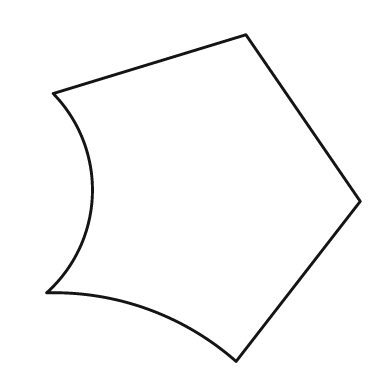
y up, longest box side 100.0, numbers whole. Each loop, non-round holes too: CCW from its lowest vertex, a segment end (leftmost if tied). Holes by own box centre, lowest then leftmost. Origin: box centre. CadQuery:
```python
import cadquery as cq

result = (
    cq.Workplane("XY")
    .moveTo(10.0, -50.0)
    .lineTo(48.0, -1.0)
    .lineTo(13.0, 50.0)
    .lineTo(-46.0, 32.0)
    .threePointArc((-34.0, 1.0), (-48.0, -29.0))
    .threePointArc((-17.0, -34.0), (10.0, -50.0))
    .close()
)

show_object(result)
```